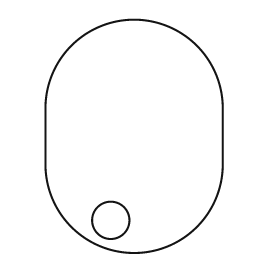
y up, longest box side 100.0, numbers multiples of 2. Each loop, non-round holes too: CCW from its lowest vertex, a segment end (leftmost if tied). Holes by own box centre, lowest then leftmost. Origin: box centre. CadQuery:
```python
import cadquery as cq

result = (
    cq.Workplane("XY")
    .moveTo(-38.0, -12.0)
    .threePointArc((0.0, -50.0), (38.0, -12.0))
    .lineTo(38.0, 12.0)
    .threePointArc((0.0, 50.0), (-38.0, 12.0))
    .close()
    .moveTo(-10.0, -36.0)
    .circle(8.0)
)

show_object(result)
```